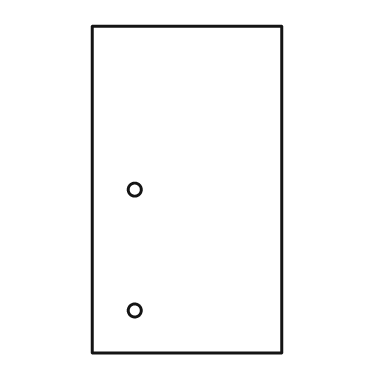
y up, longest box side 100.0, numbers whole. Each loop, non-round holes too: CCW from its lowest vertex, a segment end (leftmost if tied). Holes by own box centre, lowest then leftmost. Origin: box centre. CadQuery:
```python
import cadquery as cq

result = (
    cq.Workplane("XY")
    .moveTo(-29.0, -50.0)
    .lineTo(29.0, -50.0)
    .lineTo(29.0, 50.0)
    .lineTo(-29.0, 50.0)
    .close()
    .moveTo(-16.0, -37.0)
    .circle(2.0)
    .moveTo(-16.0, 0.0)
    .circle(2.0)
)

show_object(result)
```